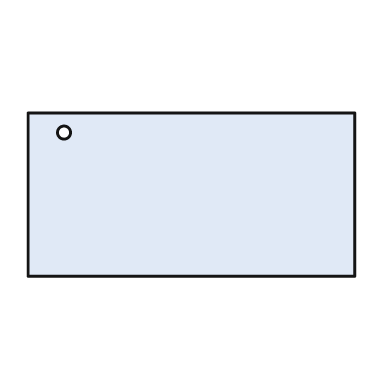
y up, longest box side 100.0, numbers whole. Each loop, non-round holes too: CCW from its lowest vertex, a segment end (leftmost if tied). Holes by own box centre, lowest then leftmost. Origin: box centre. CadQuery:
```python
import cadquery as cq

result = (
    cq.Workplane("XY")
    .moveTo(-50.0, -25.0)
    .lineTo(50.0, -25.0)
    .lineTo(50.0, 25.0)
    .lineTo(-50.0, 25.0)
    .close()
    .moveTo(-39.0, 19.0)
    .circle(2.0)
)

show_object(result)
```